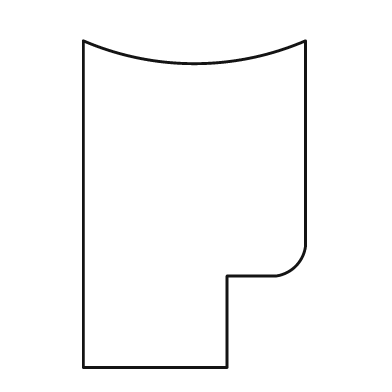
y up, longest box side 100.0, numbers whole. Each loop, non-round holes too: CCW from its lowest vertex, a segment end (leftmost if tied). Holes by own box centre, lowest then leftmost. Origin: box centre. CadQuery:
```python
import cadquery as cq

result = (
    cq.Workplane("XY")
    .moveTo(-34.0, -50.0)
    .lineTo(10.0, -50.0)
    .lineTo(10.0, -22.0)
    .lineTo(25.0, -22.0)
    .threePointArc((31.0, -19.0), (34.0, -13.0))
    .lineTo(34.0, 50.0)
    .threePointArc((0.0, 43.0), (-34.0, 50.0))
    .close()
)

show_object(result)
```